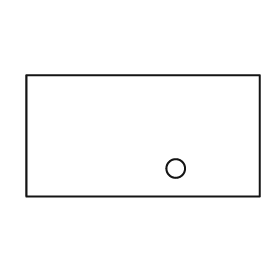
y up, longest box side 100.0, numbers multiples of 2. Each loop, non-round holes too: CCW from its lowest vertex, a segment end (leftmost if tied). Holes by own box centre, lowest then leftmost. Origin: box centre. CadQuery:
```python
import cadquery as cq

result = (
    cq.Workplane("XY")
    .moveTo(-50.0, -26.0)
    .lineTo(50.0, -26.0)
    .lineTo(50.0, 26.0)
    .lineTo(-50.0, 26.0)
    .close()
    .moveTo(14.0, -14.0)
    .circle(4.0)
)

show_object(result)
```